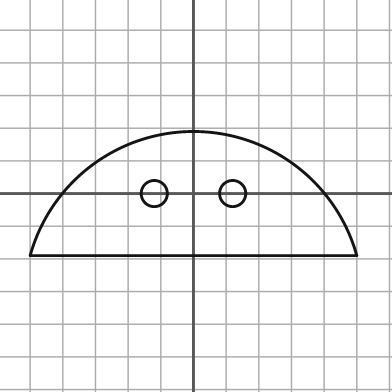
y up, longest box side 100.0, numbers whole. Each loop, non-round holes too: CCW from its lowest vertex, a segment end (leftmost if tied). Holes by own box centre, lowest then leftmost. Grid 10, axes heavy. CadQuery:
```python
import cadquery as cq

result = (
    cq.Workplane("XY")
    .moveTo(-50.0, -19.0)
    .lineTo(50.0, -19.0)
    .threePointArc((0.0, 19.0), (-50.0, -19.0))
    .close()
    .moveTo(-12.0, 0.0)
    .circle(4.0)
    .moveTo(12.0, 0.0)
    .circle(4.0)
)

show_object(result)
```